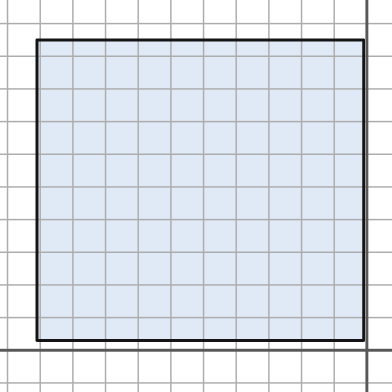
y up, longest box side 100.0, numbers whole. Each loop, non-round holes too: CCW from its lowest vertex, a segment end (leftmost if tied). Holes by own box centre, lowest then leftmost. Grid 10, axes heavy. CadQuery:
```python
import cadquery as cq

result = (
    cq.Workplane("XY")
    .moveTo(-101.0, 3.0)
    .lineTo(-1.0, 3.0)
    .lineTo(-1.0, 95.0)
    .lineTo(-101.0, 95.0)
    .close()
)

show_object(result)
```